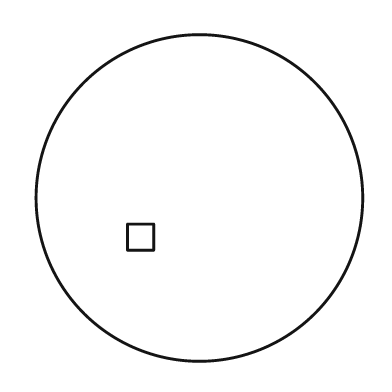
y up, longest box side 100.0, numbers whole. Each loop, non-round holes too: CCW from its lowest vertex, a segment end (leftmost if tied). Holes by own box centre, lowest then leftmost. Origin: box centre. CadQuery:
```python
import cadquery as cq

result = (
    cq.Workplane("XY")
    .moveTo(0.0, 0.0)
    .circle(50.0)
    .moveTo(-22.0, -16.0)
    .lineTo(-14.0, -16.0)
    .lineTo(-14.0, -8.0)
    .lineTo(-22.0, -8.0)
    .close()
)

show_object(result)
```